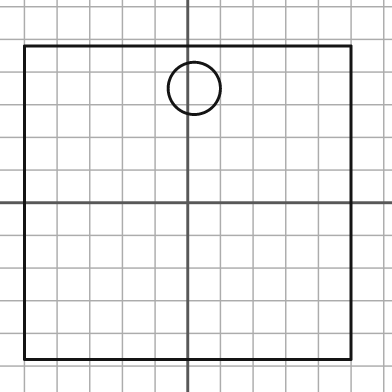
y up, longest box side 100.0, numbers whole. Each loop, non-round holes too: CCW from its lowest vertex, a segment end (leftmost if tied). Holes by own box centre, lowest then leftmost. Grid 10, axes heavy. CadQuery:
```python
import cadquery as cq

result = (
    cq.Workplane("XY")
    .moveTo(-50.0, -48.0)
    .lineTo(50.0, -48.0)
    .lineTo(50.0, 48.0)
    .lineTo(-50.0, 48.0)
    .close()
    .moveTo(2.0, 35.0)
    .circle(8.0)
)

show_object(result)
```